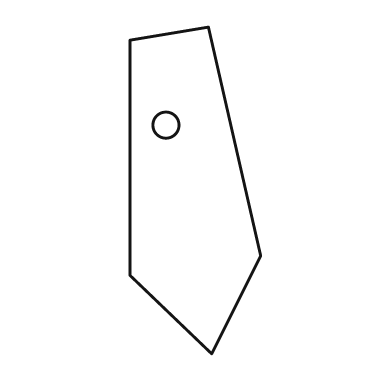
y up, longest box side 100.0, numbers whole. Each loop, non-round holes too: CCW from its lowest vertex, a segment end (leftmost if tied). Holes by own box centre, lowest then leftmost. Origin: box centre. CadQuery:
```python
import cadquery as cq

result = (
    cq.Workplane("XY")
    .moveTo(5.0, -50.0)
    .lineTo(20.0, -20.0)
    .lineTo(4.0, 50.0)
    .lineTo(-20.0, 46.0)
    .lineTo(-20.0, -26.0)
    .close()
    .moveTo(-9.0, 20.0)
    .circle(4.0)
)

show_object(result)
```